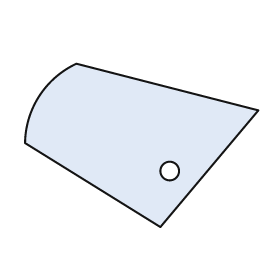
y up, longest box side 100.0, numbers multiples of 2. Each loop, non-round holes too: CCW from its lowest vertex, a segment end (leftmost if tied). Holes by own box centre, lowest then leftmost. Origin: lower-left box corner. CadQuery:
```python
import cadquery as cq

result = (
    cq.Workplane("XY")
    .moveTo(58.0, 0.0)
    .lineTo(100.0, 50.0)
    .lineTo(22.0, 70.0)
    .threePointArc((6.0, 56.0), (0.0, 36.0))
    .close()
    .moveTo(62.0, 24.0)
    .circle(4.0)
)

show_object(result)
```